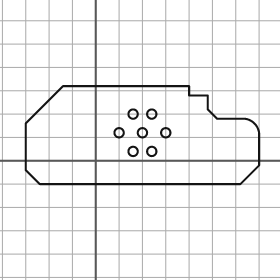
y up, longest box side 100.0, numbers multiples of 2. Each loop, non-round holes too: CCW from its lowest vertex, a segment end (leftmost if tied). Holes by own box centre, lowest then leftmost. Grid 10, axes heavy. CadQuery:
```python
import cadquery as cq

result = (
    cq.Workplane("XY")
    .moveTo(-24.0, -10.0)
    .lineTo(62.0, -10.0)
    .lineTo(70.0, -2.0)
    .lineTo(70.0, 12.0)
    .threePointArc((68.0, 16.0), (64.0, 18.0))
    .lineTo(52.0, 18.0)
    .lineTo(48.0, 22.0)
    .lineTo(48.0, 28.0)
    .lineTo(40.0, 28.0)
    .lineTo(40.0, 32.0)
    .lineTo(-14.0, 32.0)
    .lineTo(-30.0, 16.0)
    .lineTo(-30.0, -4.0)
    .close()
    .moveTo(16.0, 4.0)
    .circle(2.0)
    .moveTo(24.0, 4.0)
    .circle(2.0)
    .moveTo(10.0, 12.0)
    .circle(2.0)
    .moveTo(20.0, 12.0)
    .circle(2.0)
    .moveTo(30.0, 12.0)
    .circle(2.0)
    .moveTo(16.0, 20.0)
    .circle(2.0)
    .moveTo(24.0, 20.0)
    .circle(2.0)
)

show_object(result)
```